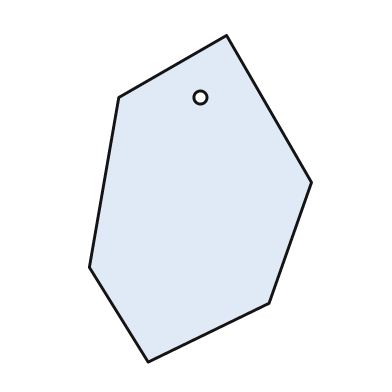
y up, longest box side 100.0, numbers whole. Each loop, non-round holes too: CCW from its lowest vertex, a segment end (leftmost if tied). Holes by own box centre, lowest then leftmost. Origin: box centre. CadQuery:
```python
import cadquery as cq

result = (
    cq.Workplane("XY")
    .moveTo(-16.0, -50.0)
    .lineTo(21.0, -32.0)
    .lineTo(34.0, 5.0)
    .lineTo(8.0, 50.0)
    .lineTo(-25.0, 31.0)
    .lineTo(-34.0, -21.0)
    .close()
    .moveTo(0.0, 31.0)
    .circle(2.0)
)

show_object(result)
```